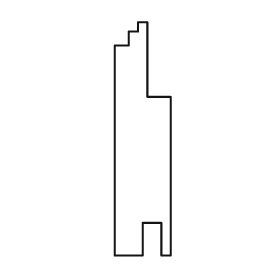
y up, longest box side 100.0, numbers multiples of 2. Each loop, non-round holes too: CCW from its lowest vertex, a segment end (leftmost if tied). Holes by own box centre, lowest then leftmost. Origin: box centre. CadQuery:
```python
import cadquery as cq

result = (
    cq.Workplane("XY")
    .moveTo(-12.0, -50.0)
    .lineTo(0.0, -50.0)
    .lineTo(0.0, -36.0)
    .lineTo(8.0, -36.0)
    .lineTo(8.0, -50.0)
    .lineTo(12.0, -50.0)
    .lineTo(12.0, 18.0)
    .lineTo(2.0, 18.0)
    .lineTo(2.0, 50.0)
    .lineTo(-2.0, 50.0)
    .lineTo(-2.0, 46.0)
    .lineTo(-6.0, 46.0)
    .lineTo(-6.0, 40.0)
    .lineTo(-12.0, 40.0)
    .close()
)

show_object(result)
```